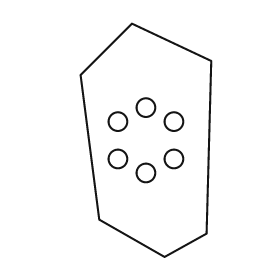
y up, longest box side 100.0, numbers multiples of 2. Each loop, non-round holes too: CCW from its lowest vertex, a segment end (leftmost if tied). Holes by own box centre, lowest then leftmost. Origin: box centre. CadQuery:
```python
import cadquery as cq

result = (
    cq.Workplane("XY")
    .moveTo(8.0, -50.0)
    .lineTo(26.0, -40.0)
    .lineTo(28.0, 34.0)
    .lineTo(-6.0, 50.0)
    .lineTo(-28.0, 28.0)
    .lineTo(-20.0, -34.0)
    .close()
    .moveTo(0.0, -14.0)
    .circle(4.0)
    .moveTo(-12.0, -8.0)
    .circle(4.0)
    .moveTo(12.0, -8.0)
    .circle(4.0)
    .moveTo(-12.0, 8.0)
    .circle(4.0)
    .moveTo(12.0, 8.0)
    .circle(4.0)
    .moveTo(0.0, 14.0)
    .circle(4.0)
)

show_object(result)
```